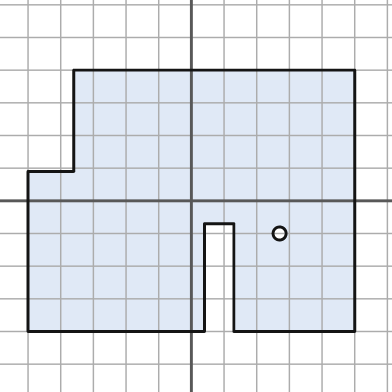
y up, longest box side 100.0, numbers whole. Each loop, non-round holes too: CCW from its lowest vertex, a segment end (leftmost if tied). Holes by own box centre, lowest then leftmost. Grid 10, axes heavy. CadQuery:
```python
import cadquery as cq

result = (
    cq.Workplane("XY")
    .moveTo(-50.0, -40.0)
    .lineTo(4.0, -40.0)
    .lineTo(4.0, -7.0)
    .lineTo(13.0, -7.0)
    .lineTo(13.0, -40.0)
    .lineTo(50.0, -40.0)
    .lineTo(50.0, 40.0)
    .lineTo(-36.0, 40.0)
    .lineTo(-36.0, 9.0)
    .lineTo(-50.0, 9.0)
    .close()
    .moveTo(27.0, -10.0)
    .circle(2.0)
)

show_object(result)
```